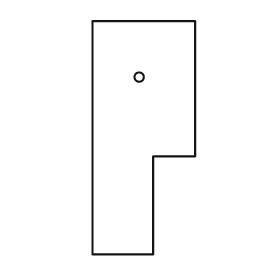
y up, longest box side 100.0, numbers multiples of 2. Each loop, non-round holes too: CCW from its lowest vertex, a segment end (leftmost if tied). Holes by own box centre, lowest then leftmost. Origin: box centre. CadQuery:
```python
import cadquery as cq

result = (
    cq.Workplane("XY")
    .moveTo(-22.0, -50.0)
    .lineTo(4.0, -50.0)
    .lineTo(4.0, -8.0)
    .lineTo(22.0, -8.0)
    .lineTo(22.0, 50.0)
    .lineTo(-22.0, 50.0)
    .close()
    .moveTo(-2.0, 26.0)
    .circle(2.0)
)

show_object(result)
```